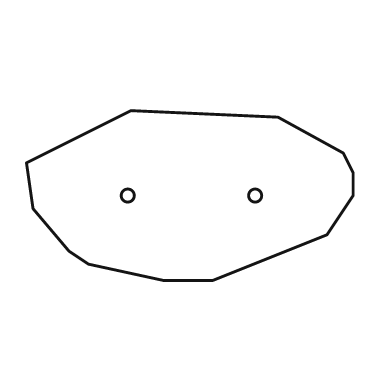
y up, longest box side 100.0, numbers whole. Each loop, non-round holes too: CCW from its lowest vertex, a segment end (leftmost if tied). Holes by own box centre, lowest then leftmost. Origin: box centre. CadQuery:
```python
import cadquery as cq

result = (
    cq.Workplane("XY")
    .moveTo(-8.0, -26.0)
    .lineTo(7.0, -26.0)
    .lineTo(42.0, -12.0)
    .lineTo(50.0, 0.0)
    .lineTo(50.0, 7.0)
    .lineTo(47.0, 13.0)
    .lineTo(27.0, 24.0)
    .lineTo(-18.0, 26.0)
    .lineTo(-50.0, 10.0)
    .lineTo(-48.0, -4.0)
    .lineTo(-37.0, -17.0)
    .lineTo(-31.0, -21.0)
    .close()
    .moveTo(-19.0, 0.0)
    .circle(2.0)
    .moveTo(20.0, 0.0)
    .circle(2.0)
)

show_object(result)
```